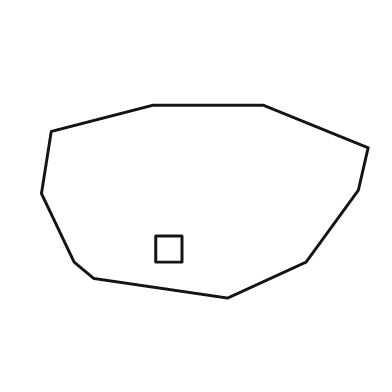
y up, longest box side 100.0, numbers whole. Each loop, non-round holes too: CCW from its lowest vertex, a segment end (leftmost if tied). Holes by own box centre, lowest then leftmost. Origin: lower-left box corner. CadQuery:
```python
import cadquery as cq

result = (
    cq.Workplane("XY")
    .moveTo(57.0, 0.0)
    .lineTo(81.0, 11.0)
    .lineTo(97.0, 33.0)
    .lineTo(100.0, 46.0)
    .lineTo(68.0, 59.0)
    .lineTo(34.0, 59.0)
    .lineTo(3.0, 51.0)
    .lineTo(0.0, 32.0)
    .lineTo(10.0, 11.0)
    .lineTo(16.0, 6.0)
    .close()
    .moveTo(35.0, 11.0)
    .lineTo(43.0, 11.0)
    .lineTo(43.0, 19.0)
    .lineTo(35.0, 19.0)
    .close()
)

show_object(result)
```